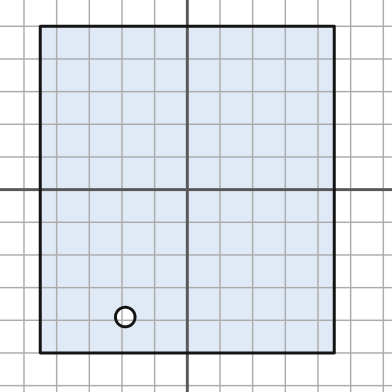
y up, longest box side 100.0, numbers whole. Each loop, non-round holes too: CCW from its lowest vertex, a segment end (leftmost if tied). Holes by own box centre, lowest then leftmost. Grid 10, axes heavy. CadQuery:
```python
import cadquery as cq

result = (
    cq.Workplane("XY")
    .moveTo(-45.0, -50.0)
    .lineTo(45.0, -50.0)
    .lineTo(45.0, 50.0)
    .lineTo(-45.0, 50.0)
    .close()
    .moveTo(-19.0, -39.0)
    .circle(3.0)
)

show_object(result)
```